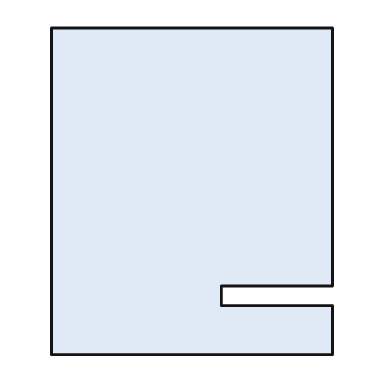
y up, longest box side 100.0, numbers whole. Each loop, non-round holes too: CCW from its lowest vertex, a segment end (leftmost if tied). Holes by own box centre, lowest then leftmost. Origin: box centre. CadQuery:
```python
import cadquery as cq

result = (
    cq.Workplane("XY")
    .moveTo(-43.0, -50.0)
    .lineTo(43.0, -50.0)
    .lineTo(43.0, -35.0)
    .lineTo(9.0, -35.0)
    .lineTo(9.0, -29.0)
    .lineTo(43.0, -29.0)
    .lineTo(43.0, 50.0)
    .lineTo(-43.0, 50.0)
    .close()
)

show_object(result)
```